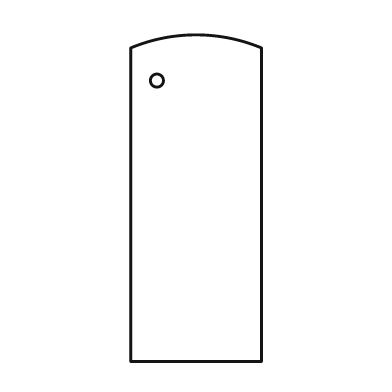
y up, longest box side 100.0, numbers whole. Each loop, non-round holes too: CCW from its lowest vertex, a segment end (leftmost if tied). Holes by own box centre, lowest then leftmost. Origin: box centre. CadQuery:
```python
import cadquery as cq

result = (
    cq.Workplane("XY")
    .moveTo(-20.0, -50.0)
    .lineTo(20.0, -50.0)
    .lineTo(20.0, 46.0)
    .threePointArc((0.0, 50.0), (-20.0, 46.0))
    .close()
    .moveTo(-12.0, 36.0)
    .circle(2.0)
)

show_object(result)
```